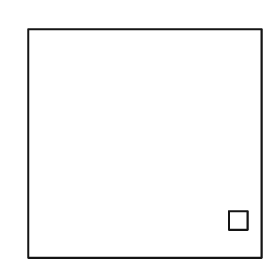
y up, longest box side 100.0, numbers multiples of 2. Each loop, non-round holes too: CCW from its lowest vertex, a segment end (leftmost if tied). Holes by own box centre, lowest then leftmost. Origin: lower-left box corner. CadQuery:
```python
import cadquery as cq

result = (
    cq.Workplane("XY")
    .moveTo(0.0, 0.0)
    .lineTo(100.0, 0.0)
    .lineTo(100.0, 98.0)
    .lineTo(0.0, 98.0)
    .close()
    .moveTo(86.0, 12.0)
    .lineTo(94.0, 12.0)
    .lineTo(94.0, 20.0)
    .lineTo(86.0, 20.0)
    .close()
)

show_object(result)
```